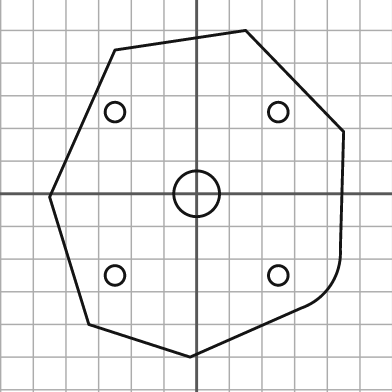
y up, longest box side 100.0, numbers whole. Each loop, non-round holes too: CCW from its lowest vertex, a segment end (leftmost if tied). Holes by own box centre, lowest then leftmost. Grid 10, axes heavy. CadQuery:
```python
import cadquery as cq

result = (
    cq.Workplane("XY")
    .moveTo(-2.0, -50.0)
    .lineTo(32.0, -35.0)
    .threePointArc((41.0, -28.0), (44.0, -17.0))
    .lineTo(45.0, 19.0)
    .lineTo(15.0, 50.0)
    .lineTo(-25.0, 44.0)
    .lineTo(-45.0, -1.0)
    .lineTo(-33.0, -40.0)
    .close()
    .moveTo(-25.0, -25.0)
    .circle(3.0)
    .moveTo(25.0, -25.0)
    .circle(3.0)
    .moveTo(0.0, 0.0)
    .circle(7.0)
    .moveTo(-25.0, 25.0)
    .circle(3.0)
    .moveTo(25.0, 25.0)
    .circle(3.0)
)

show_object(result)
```